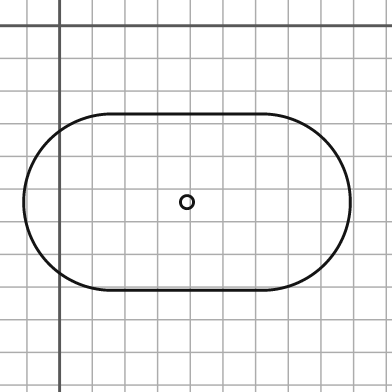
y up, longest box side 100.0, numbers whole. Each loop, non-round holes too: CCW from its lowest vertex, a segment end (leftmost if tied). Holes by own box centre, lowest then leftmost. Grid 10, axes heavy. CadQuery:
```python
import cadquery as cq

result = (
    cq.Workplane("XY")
    .moveTo(16.0, -81.0)
    .lineTo(62.0, -81.0)
    .threePointArc((89.0, -54.0), (62.0, -27.0))
    .lineTo(16.0, -27.0)
    .threePointArc((-11.0, -54.0), (16.0, -81.0))
    .close()
    .moveTo(39.0, -54.0)
    .circle(2.0)
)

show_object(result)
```